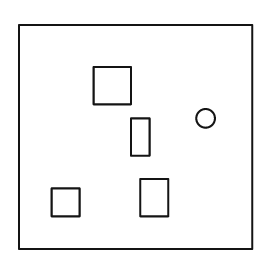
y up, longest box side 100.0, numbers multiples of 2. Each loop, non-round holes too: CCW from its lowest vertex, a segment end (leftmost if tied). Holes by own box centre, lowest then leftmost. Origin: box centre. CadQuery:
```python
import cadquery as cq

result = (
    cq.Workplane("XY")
    .moveTo(-50.0, -48.0)
    .lineTo(50.0, -48.0)
    .lineTo(50.0, 48.0)
    .lineTo(-50.0, 48.0)
    .close()
    .moveTo(-36.0, -34.0)
    .lineTo(-24.0, -34.0)
    .lineTo(-24.0, -22.0)
    .lineTo(-36.0, -22.0)
    .close()
    .moveTo(2.0, -34.0)
    .lineTo(14.0, -34.0)
    .lineTo(14.0, -18.0)
    .lineTo(2.0, -18.0)
    .close()
    .moveTo(-2.0, -8.0)
    .lineTo(6.0, -8.0)
    .lineTo(6.0, 8.0)
    .lineTo(-2.0, 8.0)
    .close()
    .moveTo(30.0, 8.0)
    .circle(4.0)
    .moveTo(-18.0, 14.0)
    .lineTo(-2.0, 14.0)
    .lineTo(-2.0, 30.0)
    .lineTo(-18.0, 30.0)
    .close()
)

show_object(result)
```